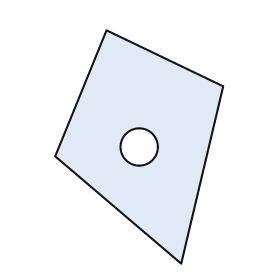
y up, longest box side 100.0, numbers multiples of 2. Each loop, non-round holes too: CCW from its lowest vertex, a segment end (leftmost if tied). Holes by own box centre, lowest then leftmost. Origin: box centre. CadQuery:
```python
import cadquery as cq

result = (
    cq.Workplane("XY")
    .moveTo(18.0, -50.0)
    .lineTo(36.0, 26.0)
    .lineTo(-14.0, 50.0)
    .lineTo(-36.0, -4.0)
    .close()
    .moveTo(0.0, 0.0)
    .circle(8.0)
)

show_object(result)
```